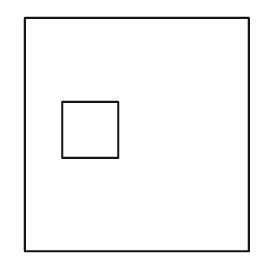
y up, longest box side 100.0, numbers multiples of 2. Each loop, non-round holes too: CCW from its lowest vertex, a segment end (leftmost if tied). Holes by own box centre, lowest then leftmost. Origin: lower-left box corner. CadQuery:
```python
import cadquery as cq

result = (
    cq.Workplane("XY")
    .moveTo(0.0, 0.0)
    .lineTo(96.0, 0.0)
    .lineTo(96.0, 100.0)
    .lineTo(0.0, 100.0)
    .close()
    .moveTo(16.0, 40.0)
    .lineTo(40.0, 40.0)
    .lineTo(40.0, 64.0)
    .lineTo(16.0, 64.0)
    .close()
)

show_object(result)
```